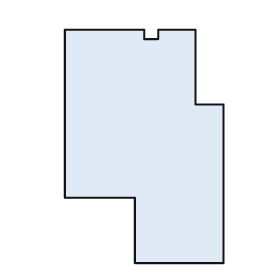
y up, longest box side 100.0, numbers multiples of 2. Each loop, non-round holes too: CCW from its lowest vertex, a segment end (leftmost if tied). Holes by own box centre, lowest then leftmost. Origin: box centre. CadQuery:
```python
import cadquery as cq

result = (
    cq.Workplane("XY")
    .moveTo(-4.0, -50.0)
    .lineTo(34.0, -50.0)
    .lineTo(34.0, 18.0)
    .lineTo(22.0, 18.0)
    .lineTo(22.0, 50.0)
    .lineTo(6.0, 50.0)
    .lineTo(6.0, 46.0)
    .lineTo(0.0, 46.0)
    .lineTo(0.0, 50.0)
    .lineTo(-34.0, 50.0)
    .lineTo(-34.0, -22.0)
    .lineTo(-4.0, -22.0)
    .close()
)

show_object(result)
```